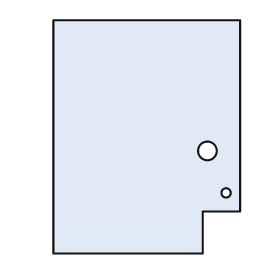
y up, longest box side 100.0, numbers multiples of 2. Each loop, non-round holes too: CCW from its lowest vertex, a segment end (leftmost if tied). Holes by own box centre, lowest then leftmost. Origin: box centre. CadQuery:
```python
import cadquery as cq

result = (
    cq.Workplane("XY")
    .moveTo(-40.0, -50.0)
    .lineTo(24.0, -50.0)
    .lineTo(24.0, -32.0)
    .lineTo(40.0, -32.0)
    .lineTo(40.0, 50.0)
    .lineTo(-40.0, 50.0)
    .close()
    .moveTo(34.0, -24.0)
    .circle(2.0)
    .moveTo(26.0, -6.0)
    .circle(4.0)
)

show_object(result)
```